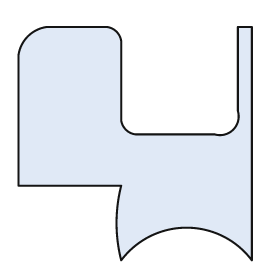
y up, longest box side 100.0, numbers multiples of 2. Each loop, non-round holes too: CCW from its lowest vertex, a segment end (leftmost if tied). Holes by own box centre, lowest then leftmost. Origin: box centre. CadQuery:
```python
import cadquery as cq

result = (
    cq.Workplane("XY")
    .moveTo(-6.0, -50.0)
    .threePointArc((22.0, -36.0), (50.0, -50.0))
    .lineTo(50.0, 50.0)
    .lineTo(44.0, 50.0)
    .lineTo(44.0, 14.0)
    .threePointArc((42.0, 6.0), (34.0, 4.0))
    .lineTo(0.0, 4.0)
    .threePointArc((-4.0, 6.0), (-6.0, 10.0))
    .lineTo(-6.0, 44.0)
    .threePointArc((-8.0, 48.0), (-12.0, 50.0))
    .lineTo(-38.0, 50.0)
    .threePointArc((-46.0, 46.0), (-50.0, 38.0))
    .lineTo(-50.0, -18.0)
    .lineTo(-6.0, -18.0)
    .threePointArc((-8.0, -34.0), (-6.0, -50.0))
    .close()
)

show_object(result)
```